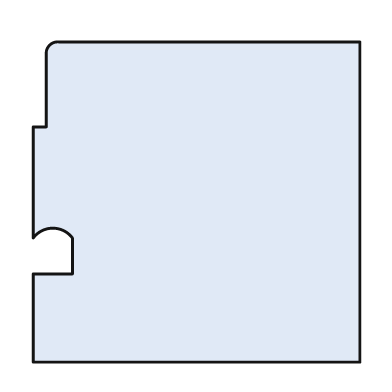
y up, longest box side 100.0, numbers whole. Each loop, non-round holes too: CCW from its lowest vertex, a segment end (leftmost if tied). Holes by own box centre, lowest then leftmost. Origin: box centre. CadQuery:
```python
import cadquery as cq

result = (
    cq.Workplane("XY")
    .moveTo(-50.0, -49.0)
    .lineTo(50.0, -49.0)
    .lineTo(50.0, 49.0)
    .lineTo(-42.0, 49.0)
    .threePointArc((-45.0, 48.0), (-46.0, 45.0))
    .lineTo(-46.0, 23.0)
    .lineTo(-50.0, 23.0)
    .lineTo(-50.0, -11.0)
    .threePointArc((-44.0, -8.0), (-38.0, -11.0))
    .lineTo(-38.0, -22.0)
    .lineTo(-50.0, -22.0)
    .close()
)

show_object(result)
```